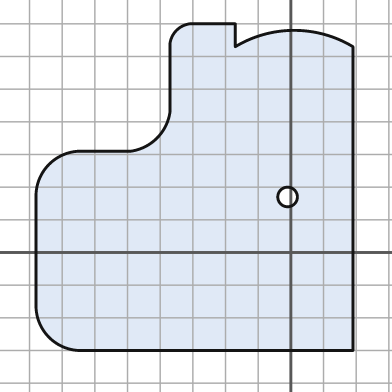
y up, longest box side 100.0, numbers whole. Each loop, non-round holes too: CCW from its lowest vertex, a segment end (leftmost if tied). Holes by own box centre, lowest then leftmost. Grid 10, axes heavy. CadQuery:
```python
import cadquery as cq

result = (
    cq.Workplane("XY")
    .moveTo(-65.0, -30.0)
    .lineTo(19.0, -30.0)
    .lineTo(19.0, 63.0)
    .threePointArc((1.0, 68.0), (-17.0, 63.0))
    .lineTo(-17.0, 70.0)
    .lineTo(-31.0, 70.0)
    .threePointArc((-35.0, 68.0), (-37.0, 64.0))
    .lineTo(-37.0, 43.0)
    .threePointArc((-41.0, 35.0), (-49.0, 31.0))
    .lineTo(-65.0, 31.0)
    .threePointArc((-74.0, 27.0), (-78.0, 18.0))
    .lineTo(-78.0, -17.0)
    .threePointArc((-74.0, -26.0), (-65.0, -30.0))
    .close()
    .moveTo(-1.0, 17.0)
    .circle(3.0)
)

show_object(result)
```